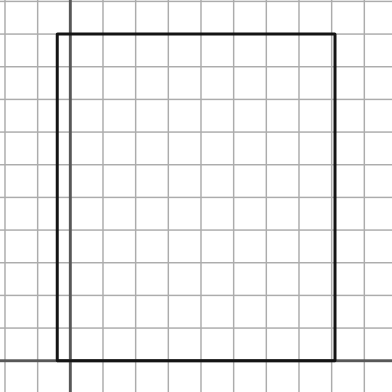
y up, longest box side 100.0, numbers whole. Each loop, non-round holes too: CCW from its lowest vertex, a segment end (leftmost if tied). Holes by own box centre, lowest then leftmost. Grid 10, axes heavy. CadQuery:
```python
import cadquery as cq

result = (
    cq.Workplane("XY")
    .moveTo(-4.0, 0.0)
    .lineTo(81.0, 0.0)
    .lineTo(81.0, 100.0)
    .lineTo(-4.0, 100.0)
    .close()
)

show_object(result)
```